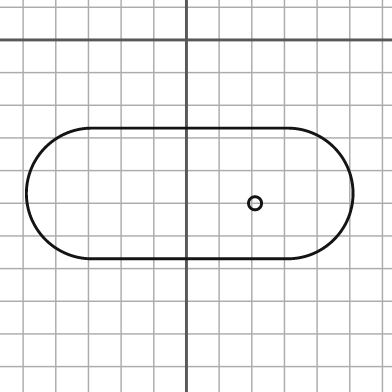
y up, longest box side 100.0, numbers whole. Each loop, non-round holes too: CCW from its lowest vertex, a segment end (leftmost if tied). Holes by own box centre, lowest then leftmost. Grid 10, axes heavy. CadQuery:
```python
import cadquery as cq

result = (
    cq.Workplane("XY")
    .moveTo(-29.0, -67.0)
    .lineTo(31.0, -67.0)
    .threePointArc((51.0, -47.0), (31.0, -27.0))
    .lineTo(-29.0, -27.0)
    .threePointArc((-49.0, -47.0), (-29.0, -67.0))
    .close()
    .moveTo(21.0, -50.0)
    .circle(2.0)
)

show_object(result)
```